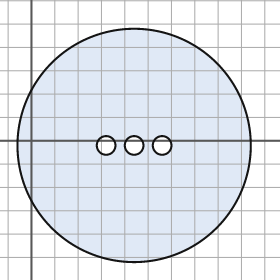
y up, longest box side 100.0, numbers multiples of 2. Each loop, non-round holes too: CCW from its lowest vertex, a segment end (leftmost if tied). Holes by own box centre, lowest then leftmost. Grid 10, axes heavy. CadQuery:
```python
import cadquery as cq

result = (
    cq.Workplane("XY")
    .moveTo(44.0, -2.0)
    .circle(50.0)
    .moveTo(32.0, -2.0)
    .circle(4.0)
    .moveTo(44.0, -2.0)
    .circle(4.0)
    .moveTo(56.0, -2.0)
    .circle(4.0)
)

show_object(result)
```